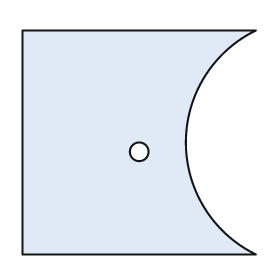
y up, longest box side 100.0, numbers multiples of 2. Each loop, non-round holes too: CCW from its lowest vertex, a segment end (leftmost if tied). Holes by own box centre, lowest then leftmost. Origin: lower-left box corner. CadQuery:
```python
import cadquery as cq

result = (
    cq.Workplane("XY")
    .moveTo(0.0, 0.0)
    .lineTo(100.0, 0.0)
    .threePointArc((70.0, 48.0), (100.0, 96.0))
    .lineTo(0.0, 96.0)
    .close()
    .moveTo(50.0, 44.0)
    .circle(4.0)
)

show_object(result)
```